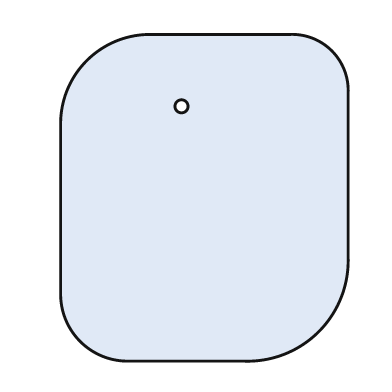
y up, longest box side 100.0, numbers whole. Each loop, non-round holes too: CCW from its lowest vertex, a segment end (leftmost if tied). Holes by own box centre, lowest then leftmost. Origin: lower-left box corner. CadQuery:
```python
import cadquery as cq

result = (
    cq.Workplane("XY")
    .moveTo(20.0, 0.0)
    .lineTo(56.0, 0.0)
    .threePointArc((79.0, 9.0), (88.0, 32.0))
    .lineTo(88.0, 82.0)
    .threePointArc((83.0, 95.0), (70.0, 100.0))
    .lineTo(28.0, 100.0)
    .threePointArc((8.0, 92.0), (0.0, 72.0))
    .lineTo(0.0, 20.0)
    .threePointArc((6.0, 6.0), (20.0, 0.0))
    .close()
    .moveTo(37.0, 78.0)
    .circle(2.0)
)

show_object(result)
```